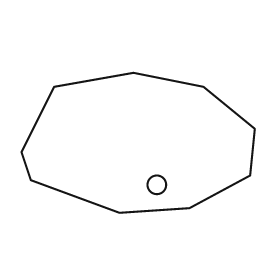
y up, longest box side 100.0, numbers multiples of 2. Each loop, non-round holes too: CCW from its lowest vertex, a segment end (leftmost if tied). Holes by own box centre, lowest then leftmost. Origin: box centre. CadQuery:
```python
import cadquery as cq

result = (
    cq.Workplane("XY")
    .moveTo(-8.0, -30.0)
    .lineTo(22.0, -28.0)
    .lineTo(48.0, -14.0)
    .lineTo(50.0, 6.0)
    .lineTo(28.0, 24.0)
    .lineTo(-2.0, 30.0)
    .lineTo(-36.0, 24.0)
    .lineTo(-50.0, -4.0)
    .lineTo(-46.0, -16.0)
    .close()
    .moveTo(8.0, -18.0)
    .circle(4.0)
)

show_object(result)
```